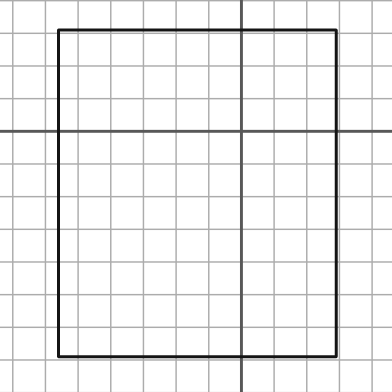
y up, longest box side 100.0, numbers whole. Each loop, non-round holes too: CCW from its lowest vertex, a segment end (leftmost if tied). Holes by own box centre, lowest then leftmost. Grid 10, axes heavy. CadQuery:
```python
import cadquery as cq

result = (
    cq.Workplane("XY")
    .moveTo(-56.0, -69.0)
    .lineTo(29.0, -69.0)
    .lineTo(29.0, 31.0)
    .lineTo(-56.0, 31.0)
    .close()
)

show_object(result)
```